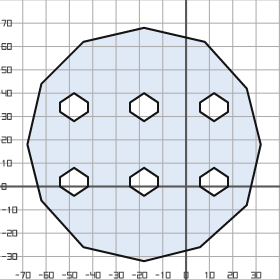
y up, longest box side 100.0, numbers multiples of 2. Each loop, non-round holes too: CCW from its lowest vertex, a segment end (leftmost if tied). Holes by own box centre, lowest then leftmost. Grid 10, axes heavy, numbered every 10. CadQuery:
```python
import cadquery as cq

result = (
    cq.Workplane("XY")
    .moveTo(-18.0, -32.0)
    .lineTo(6.0, -26.0)
    .lineTo(26.0, -8.0)
    .lineTo(32.0, 18.0)
    .lineTo(26.0, 42.0)
    .lineTo(8.0, 62.0)
    .lineTo(-18.0, 68.0)
    .lineTo(-44.0, 62.0)
    .lineTo(-62.0, 44.0)
    .lineTo(-68.0, 18.0)
    .lineTo(-62.0, -6.0)
    .lineTo(-44.0, -26.0)
    .close()
    .moveTo(-48.0, -4.0)
    .lineTo(-42.0, 0.0)
    .lineTo(-42.0, 4.0)
    .lineTo(-48.0, 8.0)
    .lineTo(-54.0, 4.0)
    .lineTo(-54.0, 0.0)
    .close()
    .moveTo(-18.0, -4.0)
    .lineTo(-12.0, 0.0)
    .lineTo(-12.0, 4.0)
    .lineTo(-18.0, 8.0)
    .lineTo(-24.0, 4.0)
    .lineTo(-24.0, 0.0)
    .close()
    .moveTo(12.0, -4.0)
    .lineTo(18.0, 0.0)
    .lineTo(18.0, 4.0)
    .lineTo(12.0, 8.0)
    .lineTo(6.0, 4.0)
    .lineTo(6.0, 0.0)
    .close()
    .moveTo(-48.0, 28.0)
    .lineTo(-42.0, 32.0)
    .lineTo(-42.0, 36.0)
    .lineTo(-48.0, 40.0)
    .lineTo(-54.0, 36.0)
    .lineTo(-54.0, 32.0)
    .close()
    .moveTo(-18.0, 28.0)
    .lineTo(-12.0, 32.0)
    .lineTo(-12.0, 36.0)
    .lineTo(-18.0, 40.0)
    .lineTo(-24.0, 36.0)
    .lineTo(-24.0, 32.0)
    .close()
    .moveTo(12.0, 28.0)
    .lineTo(18.0, 32.0)
    .lineTo(18.0, 36.0)
    .lineTo(12.0, 40.0)
    .lineTo(6.0, 36.0)
    .lineTo(6.0, 32.0)
    .close()
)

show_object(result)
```